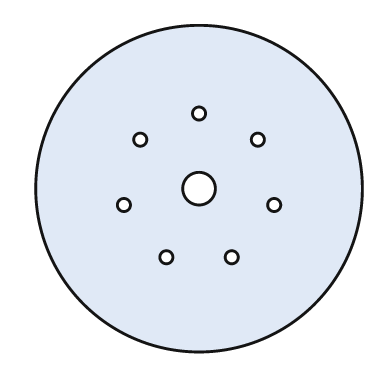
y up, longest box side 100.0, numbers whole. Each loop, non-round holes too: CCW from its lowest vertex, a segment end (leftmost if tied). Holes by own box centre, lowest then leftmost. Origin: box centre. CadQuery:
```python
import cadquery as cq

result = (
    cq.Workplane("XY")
    .moveTo(0.0, 0.0)
    .circle(50.0)
    .moveTo(-10.0, -21.0)
    .circle(2.0)
    .moveTo(10.0, -21.0)
    .circle(2.0)
    .moveTo(-23.0, -5.0)
    .circle(2.0)
    .moveTo(23.0, -5.0)
    .circle(2.0)
    .moveTo(0.0, 0.0)
    .circle(5.0)
    .moveTo(-18.0, 15.0)
    .circle(2.0)
    .moveTo(18.0, 15.0)
    .circle(2.0)
    .moveTo(0.0, 23.0)
    .circle(2.0)
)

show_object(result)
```